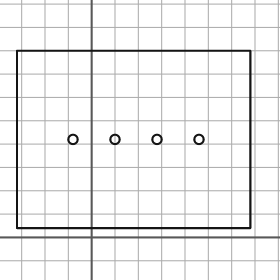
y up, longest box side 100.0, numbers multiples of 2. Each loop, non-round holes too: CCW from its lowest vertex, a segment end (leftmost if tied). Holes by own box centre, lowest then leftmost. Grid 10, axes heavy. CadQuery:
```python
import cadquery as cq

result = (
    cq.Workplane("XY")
    .moveTo(-32.0, 4.0)
    .lineTo(68.0, 4.0)
    .lineTo(68.0, 80.0)
    .lineTo(-32.0, 80.0)
    .close()
    .moveTo(-8.0, 42.0)
    .circle(2.0)
    .moveTo(10.0, 42.0)
    .circle(2.0)
    .moveTo(28.0, 42.0)
    .circle(2.0)
    .moveTo(46.0, 42.0)
    .circle(2.0)
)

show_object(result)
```